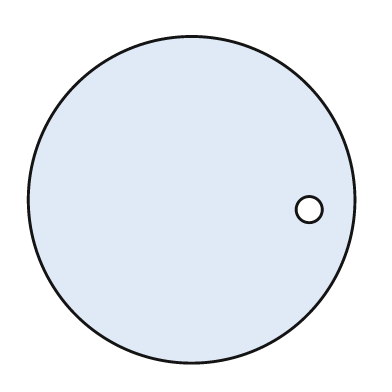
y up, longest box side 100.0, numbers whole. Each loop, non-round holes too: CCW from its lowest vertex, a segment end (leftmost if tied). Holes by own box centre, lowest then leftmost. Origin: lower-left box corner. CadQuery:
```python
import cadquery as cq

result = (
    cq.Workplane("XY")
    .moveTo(50.0, 50.0)
    .circle(50.0)
    .moveTo(86.0, 47.0)
    .circle(4.0)
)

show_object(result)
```